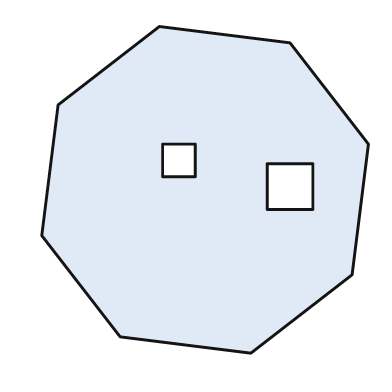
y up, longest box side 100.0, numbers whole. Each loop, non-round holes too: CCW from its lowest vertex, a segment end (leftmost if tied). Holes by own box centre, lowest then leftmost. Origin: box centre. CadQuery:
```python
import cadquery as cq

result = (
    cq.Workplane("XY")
    .moveTo(14.0, -50.0)
    .lineTo(45.0, -26.0)
    .lineTo(50.0, 14.0)
    .lineTo(26.0, 45.0)
    .lineTo(-14.0, 50.0)
    .lineTo(-45.0, 26.0)
    .lineTo(-50.0, -14.0)
    .lineTo(-26.0, -45.0)
    .close()
    .moveTo(19.0, -6.0)
    .lineTo(33.0, -6.0)
    .lineTo(33.0, 8.0)
    .lineTo(19.0, 8.0)
    .close()
    .moveTo(-13.0, 4.0)
    .lineTo(-3.0, 4.0)
    .lineTo(-3.0, 14.0)
    .lineTo(-13.0, 14.0)
    .close()
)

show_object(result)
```